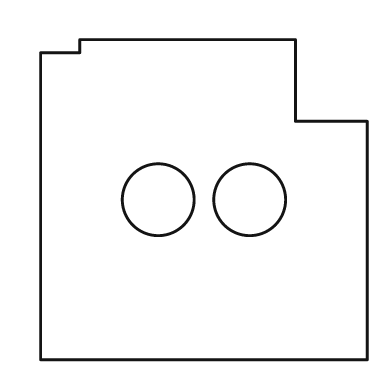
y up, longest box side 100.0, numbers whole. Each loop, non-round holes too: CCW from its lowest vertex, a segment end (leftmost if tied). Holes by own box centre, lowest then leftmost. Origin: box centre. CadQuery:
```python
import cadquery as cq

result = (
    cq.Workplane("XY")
    .moveTo(-50.0, -49.0)
    .lineTo(50.0, -49.0)
    .lineTo(50.0, 24.0)
    .lineTo(28.0, 24.0)
    .lineTo(28.0, 49.0)
    .lineTo(-38.0, 49.0)
    .lineTo(-38.0, 45.0)
    .lineTo(-50.0, 45.0)
    .close()
    .moveTo(-14.0, 0.0)
    .circle(11.0)
    .moveTo(14.0, 0.0)
    .circle(11.0)
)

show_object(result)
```